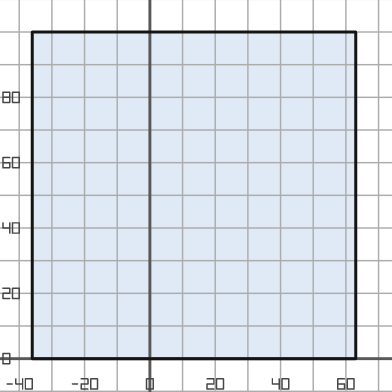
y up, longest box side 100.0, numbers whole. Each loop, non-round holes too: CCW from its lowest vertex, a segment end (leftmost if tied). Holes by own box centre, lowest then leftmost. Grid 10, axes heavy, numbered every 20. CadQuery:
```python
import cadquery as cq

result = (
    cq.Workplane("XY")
    .moveTo(-36.0, 0.0)
    .lineTo(63.0, 0.0)
    .lineTo(63.0, 100.0)
    .lineTo(-36.0, 100.0)
    .close()
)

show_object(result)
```